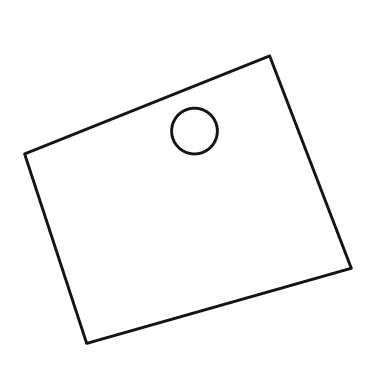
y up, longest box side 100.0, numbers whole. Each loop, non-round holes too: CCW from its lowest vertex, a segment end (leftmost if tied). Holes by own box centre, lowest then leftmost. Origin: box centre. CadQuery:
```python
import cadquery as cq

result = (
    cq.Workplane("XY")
    .moveTo(-31.0, -44.0)
    .lineTo(50.0, -21.0)
    .lineTo(25.0, 44.0)
    .lineTo(-50.0, 14.0)
    .close()
    .moveTo(2.0, 21.0)
    .circle(7.0)
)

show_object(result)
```